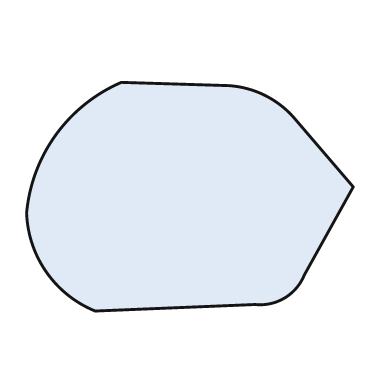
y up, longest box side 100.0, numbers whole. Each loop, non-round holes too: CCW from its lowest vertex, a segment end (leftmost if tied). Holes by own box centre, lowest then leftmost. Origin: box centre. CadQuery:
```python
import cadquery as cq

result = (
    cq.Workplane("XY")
    .moveTo(-29.0, -35.0)
    .lineTo(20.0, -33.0)
    .threePointArc((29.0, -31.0), (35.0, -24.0))
    .lineTo(50.0, 3.0)
    .lineTo(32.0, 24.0)
    .threePointArc((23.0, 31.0), (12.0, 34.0))
    .lineTo(-21.0, 35.0)
    .threePointArc((-41.0, 19.0), (-50.0, -5.0))
    .threePointArc((-44.0, -23.0), (-29.0, -35.0))
    .close()
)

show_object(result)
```